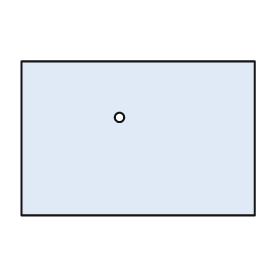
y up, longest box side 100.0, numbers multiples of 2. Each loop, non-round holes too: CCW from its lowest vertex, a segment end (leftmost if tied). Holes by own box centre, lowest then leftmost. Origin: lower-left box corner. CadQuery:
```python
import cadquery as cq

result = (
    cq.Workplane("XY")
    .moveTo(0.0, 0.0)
    .lineTo(100.0, 0.0)
    .lineTo(100.0, 66.0)
    .lineTo(0.0, 66.0)
    .close()
    .moveTo(42.0, 42.0)
    .circle(2.0)
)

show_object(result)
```